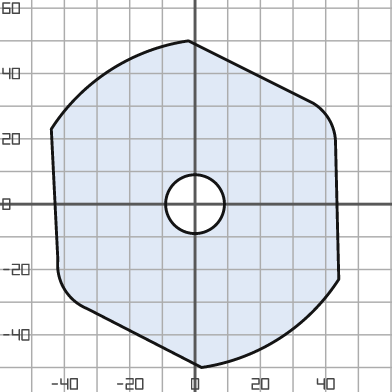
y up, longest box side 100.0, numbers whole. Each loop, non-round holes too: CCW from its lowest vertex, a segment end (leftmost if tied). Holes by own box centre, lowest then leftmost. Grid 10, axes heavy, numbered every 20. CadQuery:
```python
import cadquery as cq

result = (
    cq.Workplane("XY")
    .moveTo(2.0, -50.0)
    .threePointArc((26.0, -41.0), (44.0, -23.0))
    .lineTo(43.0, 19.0)
    .threePointArc((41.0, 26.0), (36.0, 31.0))
    .lineTo(-2.0, 50.0)
    .threePointArc((-26.0, 41.0), (-44.0, 23.0))
    .lineTo(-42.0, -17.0)
    .threePointArc((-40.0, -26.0), (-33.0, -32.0))
    .close()
    .moveTo(0.0, 0.0)
    .circle(9.0)
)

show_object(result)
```